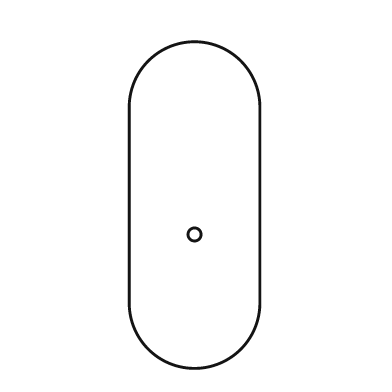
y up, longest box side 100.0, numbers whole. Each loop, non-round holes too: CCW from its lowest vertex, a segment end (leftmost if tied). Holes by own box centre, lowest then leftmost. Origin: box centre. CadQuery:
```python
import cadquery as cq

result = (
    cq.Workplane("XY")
    .moveTo(-20.0, -30.0)
    .threePointArc((0.0, -50.0), (20.0, -30.0))
    .lineTo(20.0, 30.0)
    .threePointArc((0.0, 50.0), (-20.0, 30.0))
    .close()
    .moveTo(0.0, -9.0)
    .circle(2.0)
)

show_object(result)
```